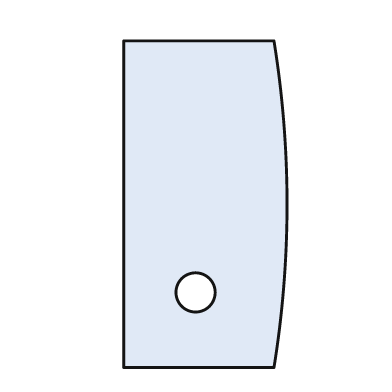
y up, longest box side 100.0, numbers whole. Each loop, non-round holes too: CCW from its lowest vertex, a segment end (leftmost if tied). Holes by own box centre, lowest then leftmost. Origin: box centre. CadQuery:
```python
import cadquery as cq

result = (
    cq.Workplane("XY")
    .moveTo(-25.0, -50.0)
    .lineTo(21.0, -50.0)
    .threePointArc((25.0, 0.0), (21.0, 50.0))
    .lineTo(-25.0, 50.0)
    .close()
    .moveTo(-3.0, -27.0)
    .circle(6.0)
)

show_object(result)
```